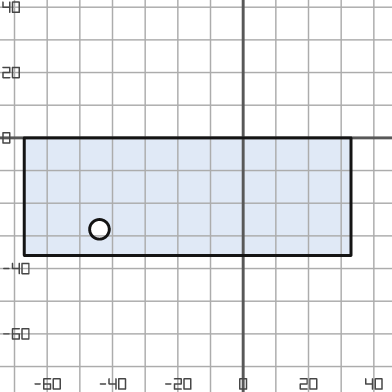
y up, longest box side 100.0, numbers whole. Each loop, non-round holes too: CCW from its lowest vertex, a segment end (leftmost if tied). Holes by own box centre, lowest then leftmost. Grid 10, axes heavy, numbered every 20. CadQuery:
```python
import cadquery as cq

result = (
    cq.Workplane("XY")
    .moveTo(-67.0, -36.0)
    .lineTo(33.0, -36.0)
    .lineTo(33.0, 0.0)
    .lineTo(-67.0, 0.0)
    .close()
    .moveTo(-44.0, -28.0)
    .circle(3.0)
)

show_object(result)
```